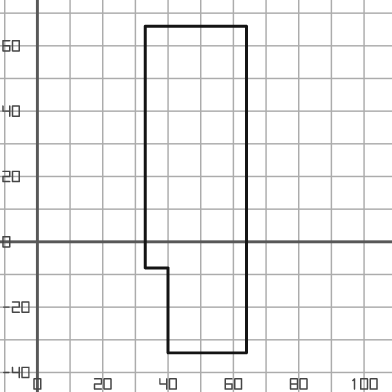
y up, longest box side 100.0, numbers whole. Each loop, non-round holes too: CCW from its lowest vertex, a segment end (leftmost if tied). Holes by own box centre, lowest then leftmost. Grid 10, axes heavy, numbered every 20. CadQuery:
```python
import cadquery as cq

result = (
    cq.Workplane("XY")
    .moveTo(40.0, -34.0)
    .lineTo(64.0, -34.0)
    .lineTo(64.0, 66.0)
    .lineTo(33.0, 66.0)
    .lineTo(33.0, -8.0)
    .lineTo(40.0, -8.0)
    .close()
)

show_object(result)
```